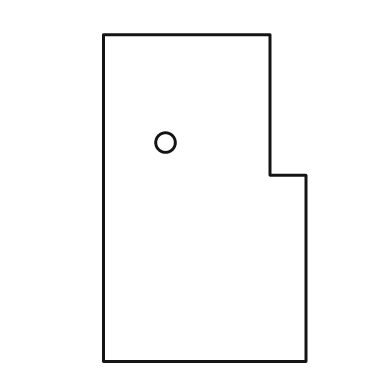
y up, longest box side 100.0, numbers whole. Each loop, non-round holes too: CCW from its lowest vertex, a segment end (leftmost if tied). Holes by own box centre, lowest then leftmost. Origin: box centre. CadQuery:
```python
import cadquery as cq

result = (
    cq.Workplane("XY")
    .moveTo(-31.0, -50.0)
    .lineTo(31.0, -50.0)
    .lineTo(31.0, 7.0)
    .lineTo(20.0, 7.0)
    .lineTo(20.0, 50.0)
    .lineTo(-31.0, 50.0)
    .close()
    .moveTo(-12.0, 17.0)
    .circle(3.0)
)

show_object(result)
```